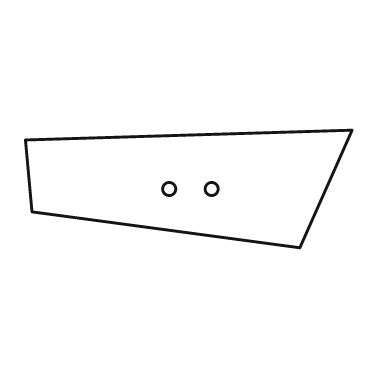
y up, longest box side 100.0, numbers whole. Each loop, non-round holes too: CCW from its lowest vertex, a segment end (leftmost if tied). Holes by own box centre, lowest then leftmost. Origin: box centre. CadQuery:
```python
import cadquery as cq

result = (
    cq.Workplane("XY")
    .moveTo(34.0, -18.0)
    .lineTo(50.0, 18.0)
    .lineTo(-50.0, 15.0)
    .lineTo(-48.0, -7.0)
    .close()
    .moveTo(-6.0, 0.0)
    .circle(2.0)
    .moveTo(7.0, 0.0)
    .circle(2.0)
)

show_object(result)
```